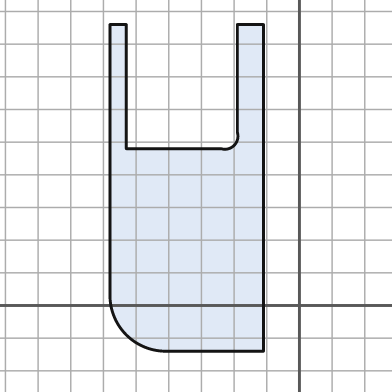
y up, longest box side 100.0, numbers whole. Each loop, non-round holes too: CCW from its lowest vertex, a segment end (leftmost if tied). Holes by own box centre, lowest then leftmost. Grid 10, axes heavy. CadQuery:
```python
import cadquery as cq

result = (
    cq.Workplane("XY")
    .moveTo(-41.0, -14.0)
    .lineTo(-11.0, -14.0)
    .lineTo(-11.0, 86.0)
    .lineTo(-19.0, 86.0)
    .lineTo(-19.0, 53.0)
    .threePointArc((-20.0, 49.0), (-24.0, 48.0))
    .lineTo(-53.0, 48.0)
    .lineTo(-53.0, 86.0)
    .lineTo(-58.0, 86.0)
    .lineTo(-58.0, 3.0)
    .threePointArc((-53.0, -9.0), (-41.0, -14.0))
    .close()
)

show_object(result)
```